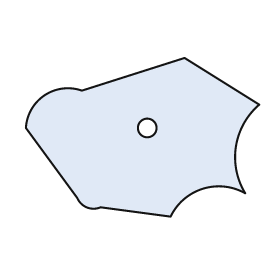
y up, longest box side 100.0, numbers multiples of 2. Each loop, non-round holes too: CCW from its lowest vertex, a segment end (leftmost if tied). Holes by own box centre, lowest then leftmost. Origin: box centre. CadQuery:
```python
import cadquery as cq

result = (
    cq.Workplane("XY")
    .moveTo(12.0, -34.0)
    .threePointArc((26.0, -22.0), (44.0, -24.0))
    .threePointArc((40.0, -4.0), (50.0, 14.0))
    .lineTo(18.0, 34.0)
    .lineTo(-26.0, 20.0)
    .threePointArc((-42.0, 18.0), (-50.0, 4.0))
    .lineTo(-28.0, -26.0)
    .threePointArc((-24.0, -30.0), (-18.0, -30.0))
    .close()
    .moveTo(2.0, 4.0)
    .circle(4.0)
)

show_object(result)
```